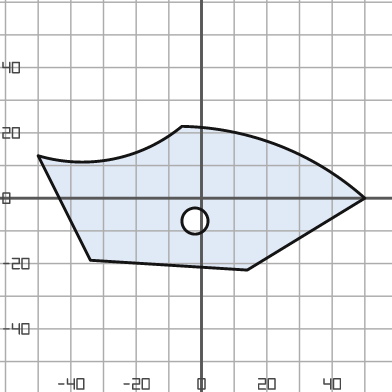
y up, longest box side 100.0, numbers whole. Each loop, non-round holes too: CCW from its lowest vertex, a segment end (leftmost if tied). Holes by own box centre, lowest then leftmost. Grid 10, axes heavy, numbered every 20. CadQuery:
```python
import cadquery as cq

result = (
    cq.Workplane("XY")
    .moveTo(14.0, -22.0)
    .lineTo(50.0, 0.0)
    .threePointArc((24.0, 16.0), (-6.0, 22.0))
    .threePointArc((-27.0, 12.0), (-50.0, 13.0))
    .lineTo(-34.0, -19.0)
    .close()
    .moveTo(-2.0, -7.0)
    .circle(4.0)
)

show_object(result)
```